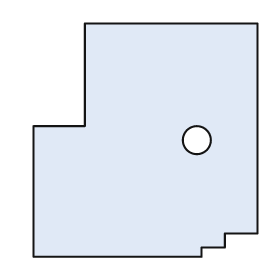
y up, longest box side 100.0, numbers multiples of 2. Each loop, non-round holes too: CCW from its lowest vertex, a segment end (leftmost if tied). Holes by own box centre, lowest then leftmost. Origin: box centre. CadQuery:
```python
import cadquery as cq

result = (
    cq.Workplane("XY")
    .moveTo(-48.0, -50.0)
    .lineTo(24.0, -50.0)
    .lineTo(24.0, -46.0)
    .lineTo(34.0, -46.0)
    .lineTo(34.0, -40.0)
    .lineTo(48.0, -40.0)
    .lineTo(48.0, 50.0)
    .lineTo(-26.0, 50.0)
    .lineTo(-26.0, 6.0)
    .lineTo(-48.0, 6.0)
    .close()
    .moveTo(22.0, 0.0)
    .circle(6.0)
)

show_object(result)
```